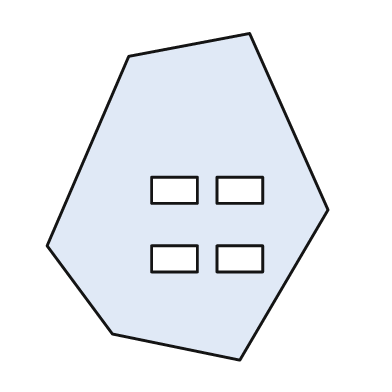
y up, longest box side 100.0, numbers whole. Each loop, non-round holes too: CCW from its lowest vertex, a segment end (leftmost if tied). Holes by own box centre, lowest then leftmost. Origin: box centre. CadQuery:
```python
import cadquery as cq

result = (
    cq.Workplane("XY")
    .moveTo(16.0, -50.0)
    .lineTo(43.0, -4.0)
    .lineTo(19.0, 50.0)
    .lineTo(-18.0, 43.0)
    .lineTo(-43.0, -15.0)
    .lineTo(-23.0, -42.0)
    .close()
    .moveTo(-11.0, -23.0)
    .lineTo(3.0, -23.0)
    .lineTo(3.0, -15.0)
    .lineTo(-11.0, -15.0)
    .close()
    .moveTo(9.0, -23.0)
    .lineTo(23.0, -23.0)
    .lineTo(23.0, -15.0)
    .lineTo(9.0, -15.0)
    .close()
    .moveTo(-11.0, -2.0)
    .lineTo(3.0, -2.0)
    .lineTo(3.0, 6.0)
    .lineTo(-11.0, 6.0)
    .close()
    .moveTo(9.0, -2.0)
    .lineTo(23.0, -2.0)
    .lineTo(23.0, 6.0)
    .lineTo(9.0, 6.0)
    .close()
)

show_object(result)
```